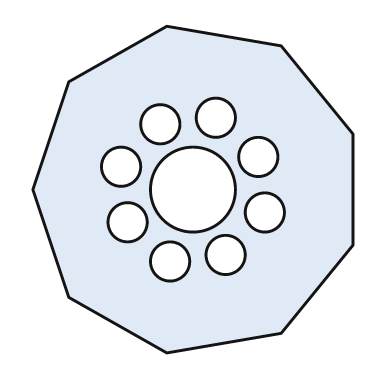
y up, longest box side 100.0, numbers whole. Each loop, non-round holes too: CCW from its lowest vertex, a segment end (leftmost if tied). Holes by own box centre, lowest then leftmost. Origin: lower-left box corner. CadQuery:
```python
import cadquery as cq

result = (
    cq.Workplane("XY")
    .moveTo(41.0, 0.0)
    .lineTo(76.0, 6.0)
    .lineTo(98.0, 33.0)
    .lineTo(98.0, 67.0)
    .lineTo(76.0, 94.0)
    .lineTo(41.0, 100.0)
    .lineTo(11.0, 83.0)
    .lineTo(0.0, 50.0)
    .lineTo(11.0, 17.0)
    .close()
    .moveTo(42.0, 28.0)
    .circle(6.0)
    .moveTo(59.0, 30.0)
    .circle(6.0)
    .moveTo(29.0, 40.0)
    .circle(6.0)
    .moveTo(71.0, 43.0)
    .circle(6.0)
    .moveTo(49.0, 50.0)
    .circle(13.0)
    .moveTo(27.0, 57.0)
    .circle(6.0)
    .moveTo(69.0, 60.0)
    .circle(6.0)
    .moveTo(39.0, 70.0)
    .circle(6.0)
    .moveTo(56.0, 72.0)
    .circle(6.0)
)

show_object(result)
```